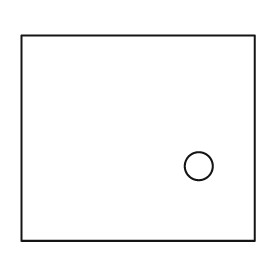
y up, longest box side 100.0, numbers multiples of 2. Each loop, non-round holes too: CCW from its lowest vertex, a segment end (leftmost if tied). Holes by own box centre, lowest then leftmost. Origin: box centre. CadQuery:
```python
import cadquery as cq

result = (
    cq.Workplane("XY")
    .moveTo(-50.0, -44.0)
    .lineTo(50.0, -44.0)
    .lineTo(50.0, 44.0)
    .lineTo(-50.0, 44.0)
    .close()
    .moveTo(26.0, -12.0)
    .circle(6.0)
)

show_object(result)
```